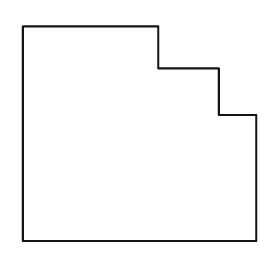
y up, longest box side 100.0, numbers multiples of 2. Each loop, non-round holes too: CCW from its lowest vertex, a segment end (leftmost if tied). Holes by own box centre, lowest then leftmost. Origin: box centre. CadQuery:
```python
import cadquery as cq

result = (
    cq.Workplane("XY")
    .moveTo(-50.0, -46.0)
    .lineTo(50.0, -46.0)
    .lineTo(50.0, 8.0)
    .lineTo(34.0, 8.0)
    .lineTo(34.0, 28.0)
    .lineTo(8.0, 28.0)
    .lineTo(8.0, 46.0)
    .lineTo(-50.0, 46.0)
    .close()
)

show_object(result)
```